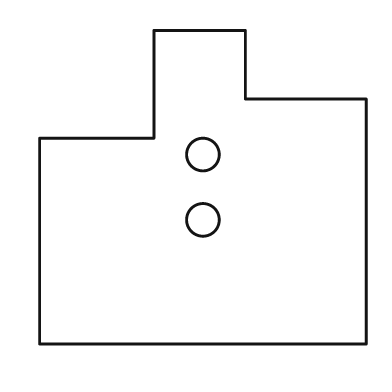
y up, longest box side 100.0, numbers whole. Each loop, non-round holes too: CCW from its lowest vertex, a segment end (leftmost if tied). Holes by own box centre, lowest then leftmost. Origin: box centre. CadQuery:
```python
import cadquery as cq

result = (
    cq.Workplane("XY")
    .moveTo(-50.0, -48.0)
    .lineTo(50.0, -48.0)
    .lineTo(50.0, 27.0)
    .lineTo(13.0, 27.0)
    .lineTo(13.0, 48.0)
    .lineTo(-15.0, 48.0)
    .lineTo(-15.0, 15.0)
    .lineTo(-50.0, 15.0)
    .close()
    .moveTo(0.0, -10.0)
    .circle(5.0)
    .moveTo(0.0, 10.0)
    .circle(5.0)
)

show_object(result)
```